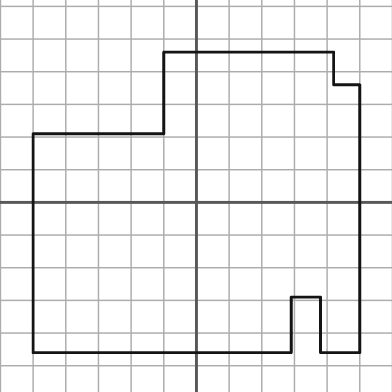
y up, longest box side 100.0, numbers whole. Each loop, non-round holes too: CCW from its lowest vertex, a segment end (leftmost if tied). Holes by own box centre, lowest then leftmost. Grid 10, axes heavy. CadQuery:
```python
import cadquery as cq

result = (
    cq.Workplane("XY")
    .moveTo(-50.0, -46.0)
    .lineTo(29.0, -46.0)
    .lineTo(29.0, -29.0)
    .lineTo(38.0, -29.0)
    .lineTo(38.0, -46.0)
    .lineTo(50.0, -46.0)
    .lineTo(50.0, 36.0)
    .lineTo(42.0, 36.0)
    .lineTo(42.0, 46.0)
    .lineTo(-10.0, 46.0)
    .lineTo(-10.0, 21.0)
    .lineTo(-50.0, 21.0)
    .close()
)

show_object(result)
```